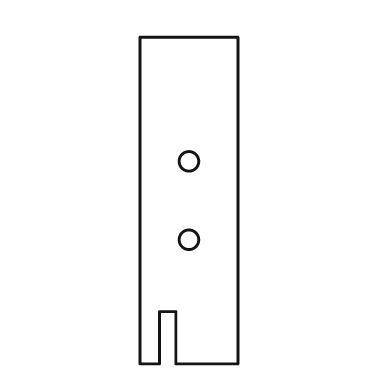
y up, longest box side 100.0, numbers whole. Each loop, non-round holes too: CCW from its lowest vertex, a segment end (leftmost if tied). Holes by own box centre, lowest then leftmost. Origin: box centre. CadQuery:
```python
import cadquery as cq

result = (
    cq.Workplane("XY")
    .moveTo(-15.0, -50.0)
    .lineTo(-9.0, -50.0)
    .lineTo(-9.0, -34.0)
    .lineTo(-4.0, -34.0)
    .lineTo(-4.0, -50.0)
    .lineTo(15.0, -50.0)
    .lineTo(15.0, 50.0)
    .lineTo(-15.0, 50.0)
    .close()
    .moveTo(0.0, -12.0)
    .circle(3.0)
    .moveTo(0.0, 12.0)
    .circle(3.0)
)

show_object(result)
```